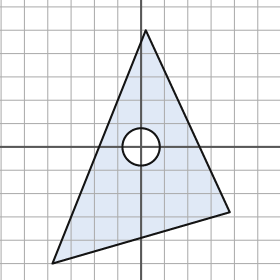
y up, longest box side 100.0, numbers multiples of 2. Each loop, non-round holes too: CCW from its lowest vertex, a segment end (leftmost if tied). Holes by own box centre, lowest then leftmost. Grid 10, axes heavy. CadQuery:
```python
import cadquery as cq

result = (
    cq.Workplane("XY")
    .moveTo(-38.0, -50.0)
    .lineTo(38.0, -28.0)
    .lineTo(2.0, 50.0)
    .close()
    .moveTo(0.0, 0.0)
    .circle(8.0)
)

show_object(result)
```